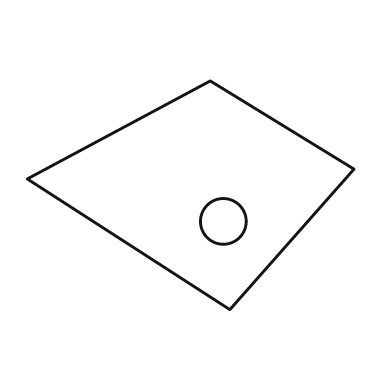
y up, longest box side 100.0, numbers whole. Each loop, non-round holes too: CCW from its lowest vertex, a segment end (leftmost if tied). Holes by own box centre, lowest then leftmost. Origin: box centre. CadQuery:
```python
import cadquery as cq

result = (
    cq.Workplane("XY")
    .moveTo(12.0, -35.0)
    .lineTo(50.0, 8.0)
    .lineTo(6.0, 35.0)
    .lineTo(-50.0, 5.0)
    .close()
    .moveTo(10.0, -8.0)
    .circle(7.0)
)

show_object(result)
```